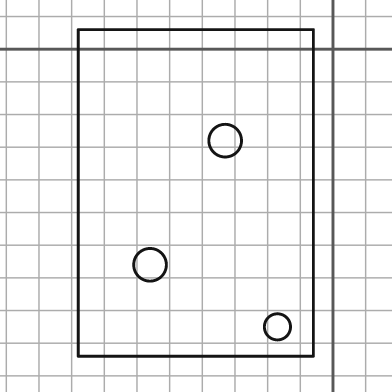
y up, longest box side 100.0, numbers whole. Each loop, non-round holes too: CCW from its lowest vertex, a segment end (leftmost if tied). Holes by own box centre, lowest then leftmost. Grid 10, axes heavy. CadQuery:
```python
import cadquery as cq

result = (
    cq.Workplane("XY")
    .moveTo(-78.0, -94.0)
    .lineTo(-6.0, -94.0)
    .lineTo(-6.0, 6.0)
    .lineTo(-78.0, 6.0)
    .close()
    .moveTo(-17.0, -85.0)
    .circle(4.0)
    .moveTo(-56.0, -66.0)
    .circle(5.0)
    .moveTo(-33.0, -28.0)
    .circle(5.0)
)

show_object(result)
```